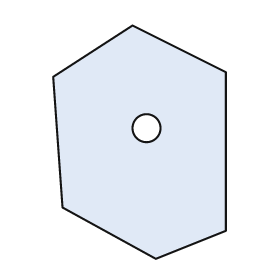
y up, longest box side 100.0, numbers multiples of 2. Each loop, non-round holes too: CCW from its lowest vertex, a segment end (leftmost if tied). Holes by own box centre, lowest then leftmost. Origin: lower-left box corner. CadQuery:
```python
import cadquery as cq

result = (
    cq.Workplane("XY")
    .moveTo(44.0, 0.0)
    .lineTo(74.0, 12.0)
    .lineTo(74.0, 80.0)
    .lineTo(34.0, 100.0)
    .lineTo(0.0, 78.0)
    .lineTo(4.0, 22.0)
    .close()
    .moveTo(40.0, 56.0)
    .circle(6.0)
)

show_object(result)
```